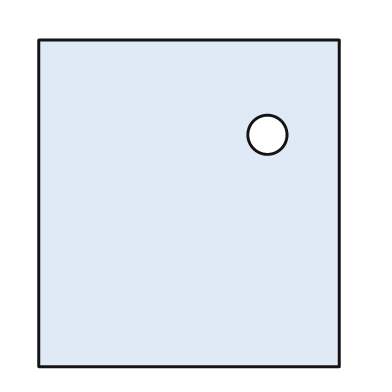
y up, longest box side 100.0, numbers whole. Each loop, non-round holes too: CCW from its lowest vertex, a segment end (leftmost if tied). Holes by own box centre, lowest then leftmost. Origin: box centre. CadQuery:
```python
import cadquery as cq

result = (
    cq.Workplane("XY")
    .moveTo(-46.0, -50.0)
    .lineTo(46.0, -50.0)
    .lineTo(46.0, 50.0)
    .lineTo(-46.0, 50.0)
    .close()
    .moveTo(24.0, 21.0)
    .circle(6.0)
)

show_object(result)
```